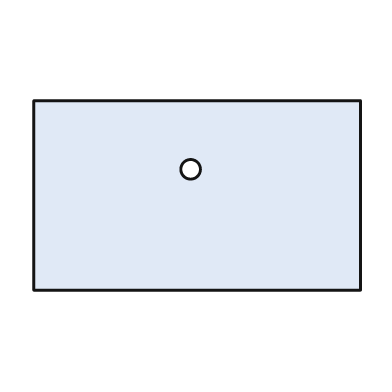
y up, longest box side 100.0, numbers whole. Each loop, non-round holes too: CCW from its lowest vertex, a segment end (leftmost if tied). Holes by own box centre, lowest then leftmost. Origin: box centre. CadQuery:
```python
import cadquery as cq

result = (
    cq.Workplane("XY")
    .moveTo(-50.0, -29.0)
    .lineTo(50.0, -29.0)
    .lineTo(50.0, 29.0)
    .lineTo(-50.0, 29.0)
    .close()
    .moveTo(-2.0, 8.0)
    .circle(3.0)
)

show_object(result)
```